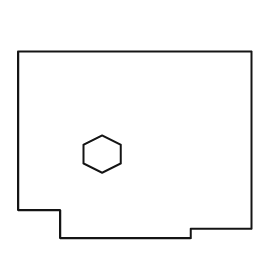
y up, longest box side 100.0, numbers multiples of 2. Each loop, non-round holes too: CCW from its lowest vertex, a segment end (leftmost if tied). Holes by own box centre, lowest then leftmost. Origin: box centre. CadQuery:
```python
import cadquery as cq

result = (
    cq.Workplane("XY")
    .moveTo(-32.0, -40.0)
    .lineTo(24.0, -40.0)
    .lineTo(24.0, -36.0)
    .lineTo(50.0, -36.0)
    .lineTo(50.0, 40.0)
    .lineTo(-50.0, 40.0)
    .lineTo(-50.0, -28.0)
    .lineTo(-32.0, -28.0)
    .close()
    .moveTo(-14.0, -12.0)
    .lineTo(-6.0, -8.0)
    .lineTo(-6.0, 0.0)
    .lineTo(-14.0, 4.0)
    .lineTo(-22.0, 0.0)
    .lineTo(-22.0, -8.0)
    .close()
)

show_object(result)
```